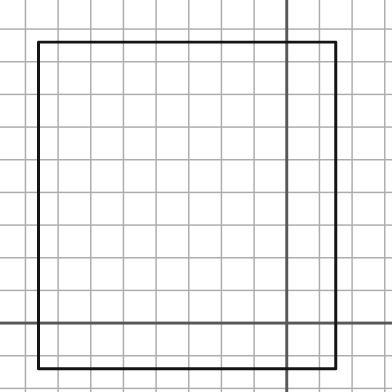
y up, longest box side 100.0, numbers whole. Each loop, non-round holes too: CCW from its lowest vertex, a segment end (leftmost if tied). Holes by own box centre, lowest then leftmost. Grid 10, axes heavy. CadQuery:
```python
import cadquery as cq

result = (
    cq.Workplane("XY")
    .moveTo(-76.0, -14.0)
    .lineTo(15.0, -14.0)
    .lineTo(15.0, 86.0)
    .lineTo(-76.0, 86.0)
    .close()
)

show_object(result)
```